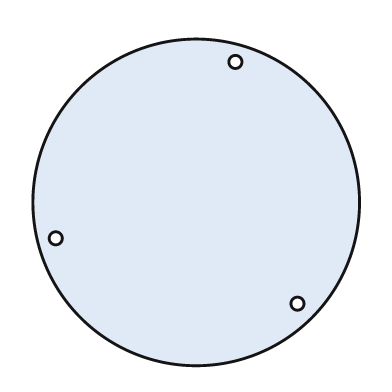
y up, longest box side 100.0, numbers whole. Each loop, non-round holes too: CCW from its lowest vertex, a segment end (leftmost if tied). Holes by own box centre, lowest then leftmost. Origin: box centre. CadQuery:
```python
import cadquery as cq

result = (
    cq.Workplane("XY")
    .moveTo(0.0, 0.0)
    .circle(50.0)
    .moveTo(31.0, -31.0)
    .circle(2.0)
    .moveTo(-43.0, -11.0)
    .circle(2.0)
    .moveTo(12.0, 43.0)
    .circle(2.0)
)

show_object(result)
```